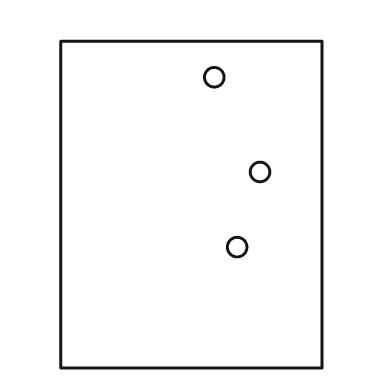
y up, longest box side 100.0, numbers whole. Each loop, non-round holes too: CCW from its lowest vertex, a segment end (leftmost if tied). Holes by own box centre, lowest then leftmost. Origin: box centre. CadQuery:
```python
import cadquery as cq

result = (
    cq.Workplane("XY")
    .moveTo(-40.0, -50.0)
    .lineTo(40.0, -50.0)
    .lineTo(40.0, 50.0)
    .lineTo(-40.0, 50.0)
    .close()
    .moveTo(14.0, -13.0)
    .circle(3.0)
    .moveTo(21.0, 10.0)
    .circle(3.0)
    .moveTo(7.0, 39.0)
    .circle(3.0)
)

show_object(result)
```